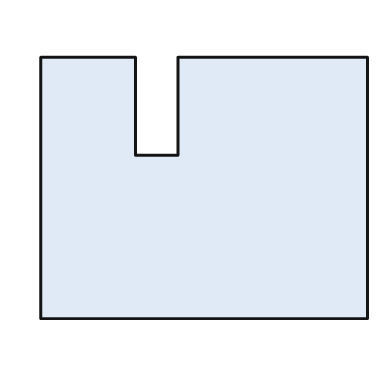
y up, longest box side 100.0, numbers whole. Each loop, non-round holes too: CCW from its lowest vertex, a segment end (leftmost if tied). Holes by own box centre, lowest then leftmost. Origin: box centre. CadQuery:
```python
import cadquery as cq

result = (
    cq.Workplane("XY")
    .moveTo(-50.0, -40.0)
    .lineTo(50.0, -40.0)
    .lineTo(50.0, 40.0)
    .lineTo(-8.0, 40.0)
    .lineTo(-8.0, 10.0)
    .lineTo(-21.0, 10.0)
    .lineTo(-21.0, 40.0)
    .lineTo(-50.0, 40.0)
    .close()
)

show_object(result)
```